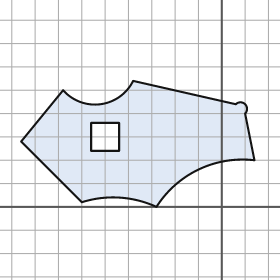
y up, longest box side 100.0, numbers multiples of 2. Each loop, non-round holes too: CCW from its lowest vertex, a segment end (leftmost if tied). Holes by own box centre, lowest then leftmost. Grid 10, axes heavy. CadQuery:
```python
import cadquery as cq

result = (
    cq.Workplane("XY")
    .moveTo(-28.0, 0.0)
    .threePointArc((-10.0, 16.0), (14.0, 20.0))
    .lineTo(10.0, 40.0)
    .threePointArc((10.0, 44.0), (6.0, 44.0))
    .lineTo(-38.0, 54.0)
    .threePointArc((-52.0, 44.0), (-68.0, 50.0))
    .lineTo(-86.0, 28.0)
    .lineTo(-60.0, 2.0)
    .threePointArc((-44.0, 4.0), (-28.0, 0.0))
    .close()
    .moveTo(-56.0, 24.0)
    .lineTo(-44.0, 24.0)
    .lineTo(-44.0, 36.0)
    .lineTo(-56.0, 36.0)
    .close()
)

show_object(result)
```